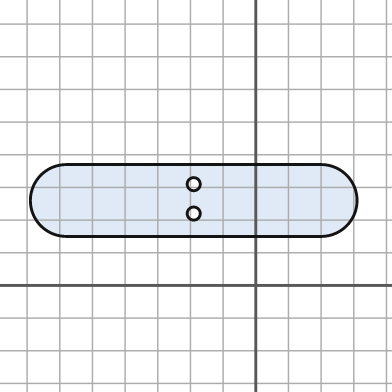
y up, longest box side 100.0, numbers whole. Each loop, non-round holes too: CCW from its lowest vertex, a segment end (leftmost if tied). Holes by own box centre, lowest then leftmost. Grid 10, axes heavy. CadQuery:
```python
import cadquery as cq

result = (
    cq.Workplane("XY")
    .moveTo(-58.0, 15.0)
    .lineTo(20.0, 15.0)
    .threePointArc((31.0, 26.0), (20.0, 37.0))
    .lineTo(-58.0, 37.0)
    .threePointArc((-69.0, 26.0), (-58.0, 15.0))
    .close()
    .moveTo(-19.0, 22.0)
    .circle(2.0)
    .moveTo(-19.0, 31.0)
    .circle(2.0)
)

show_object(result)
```